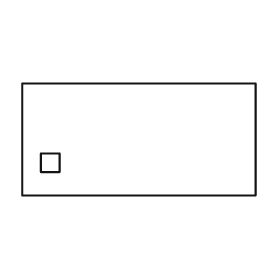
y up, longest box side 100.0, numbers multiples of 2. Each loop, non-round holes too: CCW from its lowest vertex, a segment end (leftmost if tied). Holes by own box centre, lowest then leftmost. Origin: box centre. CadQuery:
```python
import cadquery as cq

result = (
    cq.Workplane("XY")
    .moveTo(-50.0, -24.0)
    .lineTo(50.0, -24.0)
    .lineTo(50.0, 24.0)
    .lineTo(-50.0, 24.0)
    .close()
    .moveTo(-42.0, -14.0)
    .lineTo(-34.0, -14.0)
    .lineTo(-34.0, -6.0)
    .lineTo(-42.0, -6.0)
    .close()
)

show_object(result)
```